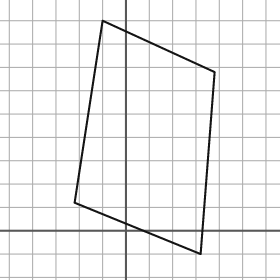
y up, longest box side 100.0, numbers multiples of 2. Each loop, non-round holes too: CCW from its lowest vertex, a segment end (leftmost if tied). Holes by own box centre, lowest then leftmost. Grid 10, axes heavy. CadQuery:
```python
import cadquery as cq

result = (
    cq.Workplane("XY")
    .moveTo(32.0, -10.0)
    .lineTo(38.0, 68.0)
    .lineTo(-10.0, 90.0)
    .lineTo(-22.0, 12.0)
    .close()
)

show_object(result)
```